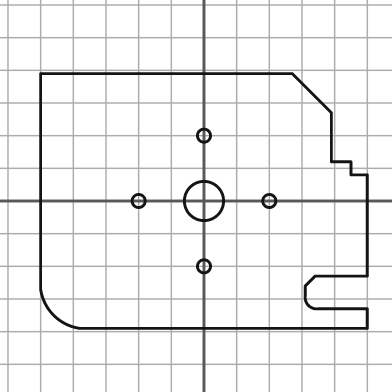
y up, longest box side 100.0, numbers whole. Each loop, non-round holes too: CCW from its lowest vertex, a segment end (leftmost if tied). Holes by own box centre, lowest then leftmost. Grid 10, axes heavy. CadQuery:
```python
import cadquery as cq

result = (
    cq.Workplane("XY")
    .moveTo(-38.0, -39.0)
    .lineTo(50.0, -39.0)
    .lineTo(50.0, -33.0)
    .lineTo(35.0, -33.0)
    .threePointArc((32.0, -32.0), (31.0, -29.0))
    .lineTo(31.0, -26.0)
    .lineTo(34.0, -23.0)
    .lineTo(50.0, -23.0)
    .lineTo(50.0, 8.0)
    .lineTo(45.0, 8.0)
    .lineTo(45.0, 12.0)
    .lineTo(39.0, 12.0)
    .lineTo(39.0, 27.0)
    .lineTo(27.0, 39.0)
    .lineTo(-50.0, 39.0)
    .lineTo(-50.0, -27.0)
    .threePointArc((-46.0, -35.0), (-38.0, -39.0))
    .close()
    .moveTo(0.0, -20.0)
    .circle(2.0)
    .moveTo(-20.0, 0.0)
    .circle(2.0)
    .moveTo(0.0, 0.0)
    .circle(6.0)
    .moveTo(20.0, 0.0)
    .circle(2.0)
    .moveTo(0.0, 20.0)
    .circle(2.0)
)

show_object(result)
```